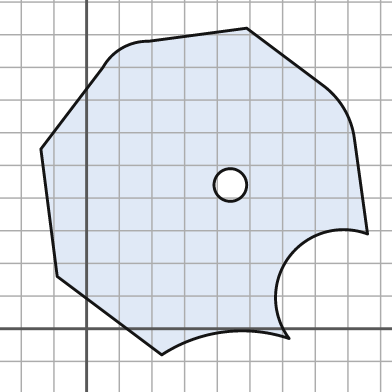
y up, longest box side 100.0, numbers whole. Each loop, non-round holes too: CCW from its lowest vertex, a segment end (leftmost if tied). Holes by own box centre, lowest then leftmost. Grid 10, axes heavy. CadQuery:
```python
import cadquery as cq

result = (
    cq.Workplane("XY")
    .moveTo(23.0, -8.0)
    .threePointArc((42.0, -1.0), (62.0, -3.0))
    .threePointArc((62.0, 22.0), (86.0, 29.0))
    .lineTo(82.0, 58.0)
    .threePointArc((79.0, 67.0), (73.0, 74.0))
    .lineTo(49.0, 92.0)
    .lineTo(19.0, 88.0)
    .threePointArc((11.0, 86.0), (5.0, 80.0))
    .lineTo(-14.0, 55.0)
    .lineTo(-9.0, 16.0)
    .close()
    .moveTo(44.0, 44.0)
    .circle(5.0)
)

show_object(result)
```